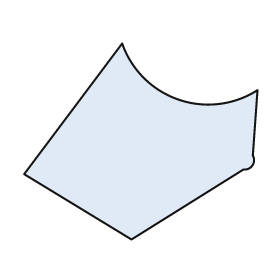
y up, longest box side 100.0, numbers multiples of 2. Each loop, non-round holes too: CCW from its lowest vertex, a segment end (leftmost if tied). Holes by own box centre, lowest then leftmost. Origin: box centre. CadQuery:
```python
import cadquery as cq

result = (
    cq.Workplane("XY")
    .moveTo(-4.0, -42.0)
    .lineTo(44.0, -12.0)
    .threePointArc((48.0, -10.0), (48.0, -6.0))
    .lineTo(50.0, 22.0)
    .threePointArc((16.0, 18.0), (-8.0, 42.0))
    .lineTo(-50.0, -14.0)
    .close()
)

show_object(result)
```